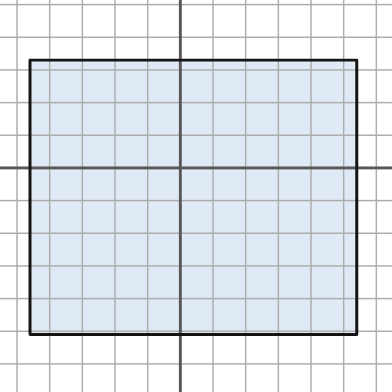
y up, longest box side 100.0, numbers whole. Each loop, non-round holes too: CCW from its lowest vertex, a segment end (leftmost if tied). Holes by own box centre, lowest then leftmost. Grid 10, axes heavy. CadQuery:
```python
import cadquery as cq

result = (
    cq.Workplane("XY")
    .moveTo(-46.0, -51.0)
    .lineTo(54.0, -51.0)
    .lineTo(54.0, 33.0)
    .lineTo(-46.0, 33.0)
    .close()
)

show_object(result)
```